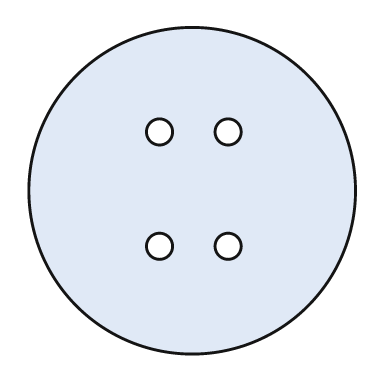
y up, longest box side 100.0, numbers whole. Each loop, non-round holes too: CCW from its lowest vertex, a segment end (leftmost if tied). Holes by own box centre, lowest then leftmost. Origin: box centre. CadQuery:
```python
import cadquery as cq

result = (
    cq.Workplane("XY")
    .moveTo(0.0, 0.0)
    .circle(50.0)
    .moveTo(-10.0, -17.0)
    .circle(4.0)
    .moveTo(11.0, -17.0)
    .circle(4.0)
    .moveTo(-10.0, 18.0)
    .circle(4.0)
    .moveTo(11.0, 18.0)
    .circle(4.0)
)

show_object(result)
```